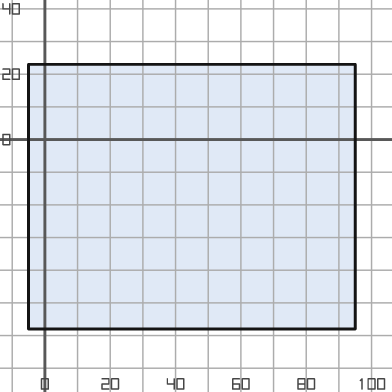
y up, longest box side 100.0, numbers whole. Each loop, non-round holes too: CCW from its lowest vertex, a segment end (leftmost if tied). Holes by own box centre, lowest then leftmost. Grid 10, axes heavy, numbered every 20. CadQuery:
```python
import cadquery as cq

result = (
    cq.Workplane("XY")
    .moveTo(-5.0, -58.0)
    .lineTo(95.0, -58.0)
    .lineTo(95.0, 23.0)
    .lineTo(-5.0, 23.0)
    .close()
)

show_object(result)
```